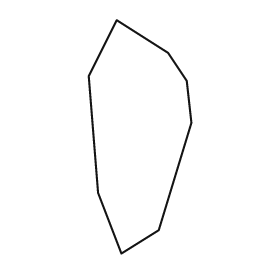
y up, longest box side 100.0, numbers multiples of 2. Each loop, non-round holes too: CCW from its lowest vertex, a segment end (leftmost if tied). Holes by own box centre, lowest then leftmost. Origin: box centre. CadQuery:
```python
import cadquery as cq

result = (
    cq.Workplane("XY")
    .moveTo(-8.0, -50.0)
    .lineTo(8.0, -40.0)
    .lineTo(22.0, 6.0)
    .lineTo(20.0, 24.0)
    .lineTo(12.0, 36.0)
    .lineTo(-10.0, 50.0)
    .lineTo(-22.0, 26.0)
    .lineTo(-18.0, -24.0)
    .close()
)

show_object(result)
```